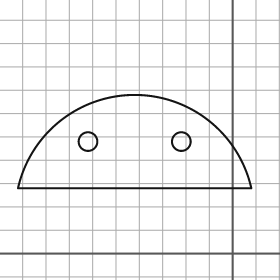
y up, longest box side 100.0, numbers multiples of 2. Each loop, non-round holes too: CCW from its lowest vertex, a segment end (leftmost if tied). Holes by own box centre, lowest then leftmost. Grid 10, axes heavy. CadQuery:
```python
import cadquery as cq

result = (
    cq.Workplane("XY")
    .moveTo(-92.0, 28.0)
    .lineTo(8.0, 28.0)
    .threePointArc((-42.0, 68.0), (-92.0, 28.0))
    .close()
    .moveTo(-62.0, 48.0)
    .circle(4.0)
    .moveTo(-22.0, 48.0)
    .circle(4.0)
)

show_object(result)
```